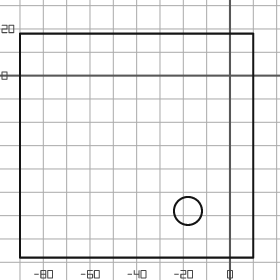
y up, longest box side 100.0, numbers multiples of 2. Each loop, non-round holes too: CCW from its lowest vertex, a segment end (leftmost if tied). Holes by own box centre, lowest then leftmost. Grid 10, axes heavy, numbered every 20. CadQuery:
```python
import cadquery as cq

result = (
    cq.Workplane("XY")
    .moveTo(-90.0, -78.0)
    .lineTo(10.0, -78.0)
    .lineTo(10.0, 18.0)
    .lineTo(-90.0, 18.0)
    .close()
    .moveTo(-18.0, -58.0)
    .circle(6.0)
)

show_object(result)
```